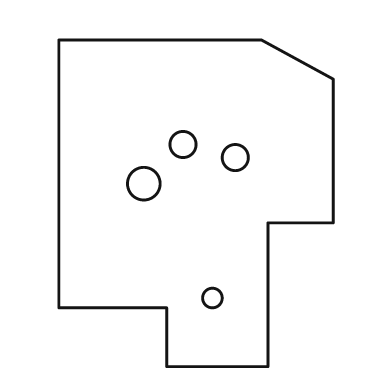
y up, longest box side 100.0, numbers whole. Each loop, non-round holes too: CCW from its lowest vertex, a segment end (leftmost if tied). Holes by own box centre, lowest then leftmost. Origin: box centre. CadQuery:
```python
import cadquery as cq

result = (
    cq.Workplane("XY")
    .moveTo(-9.0, -50.0)
    .lineTo(22.0, -50.0)
    .lineTo(22.0, -6.0)
    .lineTo(42.0, -6.0)
    .lineTo(42.0, 38.0)
    .lineTo(20.0, 50.0)
    .lineTo(-42.0, 50.0)
    .lineTo(-42.0, -32.0)
    .lineTo(-9.0, -32.0)
    .close()
    .moveTo(5.0, -29.0)
    .circle(3.0)
    .moveTo(-16.0, 6.0)
    .circle(5.0)
    .moveTo(12.0, 14.0)
    .circle(4.0)
    .moveTo(-4.0, 18.0)
    .circle(4.0)
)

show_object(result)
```